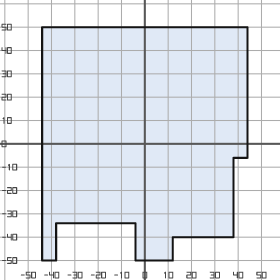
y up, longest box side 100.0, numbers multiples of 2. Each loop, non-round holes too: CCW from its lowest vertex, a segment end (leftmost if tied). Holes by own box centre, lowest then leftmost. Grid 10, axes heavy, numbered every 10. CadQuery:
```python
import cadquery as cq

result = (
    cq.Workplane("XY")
    .moveTo(-44.0, -50.0)
    .lineTo(-38.0, -50.0)
    .lineTo(-38.0, -34.0)
    .lineTo(-4.0, -34.0)
    .lineTo(-4.0, -50.0)
    .lineTo(12.0, -50.0)
    .lineTo(12.0, -40.0)
    .lineTo(38.0, -40.0)
    .lineTo(38.0, -6.0)
    .lineTo(44.0, -6.0)
    .lineTo(44.0, 50.0)
    .lineTo(-44.0, 50.0)
    .close()
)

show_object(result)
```